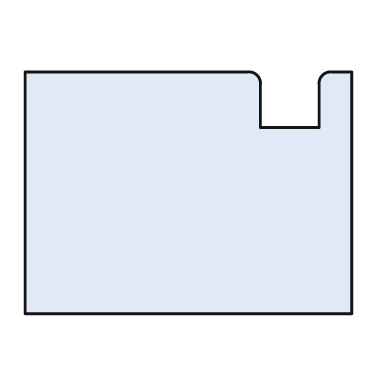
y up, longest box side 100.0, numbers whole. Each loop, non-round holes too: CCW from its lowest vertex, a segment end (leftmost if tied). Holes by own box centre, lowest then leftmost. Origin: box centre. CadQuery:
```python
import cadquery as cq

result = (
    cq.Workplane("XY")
    .moveTo(-50.0, -37.0)
    .lineTo(50.0, -37.0)
    .lineTo(50.0, 37.0)
    .lineTo(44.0, 37.0)
    .threePointArc((41.0, 36.0), (40.0, 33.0))
    .lineTo(40.0, 20.0)
    .lineTo(22.0, 20.0)
    .lineTo(22.0, 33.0)
    .threePointArc((21.0, 36.0), (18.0, 37.0))
    .lineTo(-50.0, 37.0)
    .close()
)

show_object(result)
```